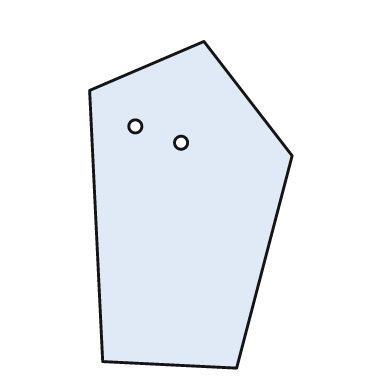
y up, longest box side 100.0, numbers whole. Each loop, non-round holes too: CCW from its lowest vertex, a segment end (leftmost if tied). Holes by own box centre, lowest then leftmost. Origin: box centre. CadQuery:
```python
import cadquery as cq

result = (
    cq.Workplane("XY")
    .moveTo(14.0, -50.0)
    .lineTo(31.0, 15.0)
    .lineTo(4.0, 50.0)
    .lineTo(-31.0, 35.0)
    .lineTo(-27.0, -48.0)
    .close()
    .moveTo(-3.0, 19.0)
    .circle(2.0)
    .moveTo(-17.0, 24.0)
    .circle(2.0)
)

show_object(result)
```